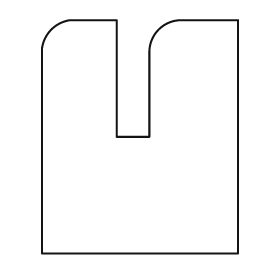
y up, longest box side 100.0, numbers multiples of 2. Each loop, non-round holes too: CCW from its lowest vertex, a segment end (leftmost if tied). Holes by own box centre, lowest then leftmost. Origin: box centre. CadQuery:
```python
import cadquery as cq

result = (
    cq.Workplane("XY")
    .moveTo(-42.0, -50.0)
    .lineTo(42.0, -50.0)
    .lineTo(42.0, 50.0)
    .lineTo(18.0, 50.0)
    .threePointArc((8.0, 46.0), (4.0, 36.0))
    .lineTo(4.0, 0.0)
    .lineTo(-10.0, 0.0)
    .lineTo(-10.0, 50.0)
    .lineTo(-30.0, 50.0)
    .threePointArc((-38.0, 46.0), (-42.0, 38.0))
    .close()
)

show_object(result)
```